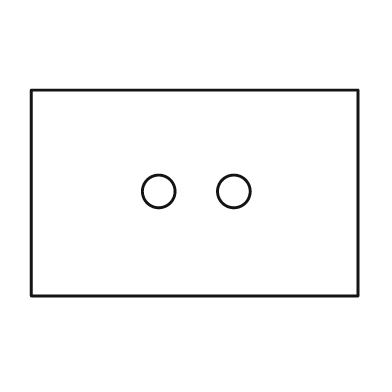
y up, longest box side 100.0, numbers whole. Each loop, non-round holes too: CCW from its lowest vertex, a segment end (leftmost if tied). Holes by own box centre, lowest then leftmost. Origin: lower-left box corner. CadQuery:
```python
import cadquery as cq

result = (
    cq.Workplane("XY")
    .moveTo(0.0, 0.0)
    .lineTo(100.0, 0.0)
    .lineTo(100.0, 63.0)
    .lineTo(0.0, 63.0)
    .close()
    .moveTo(39.0, 32.0)
    .circle(5.0)
    .moveTo(62.0, 32.0)
    .circle(5.0)
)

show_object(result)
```